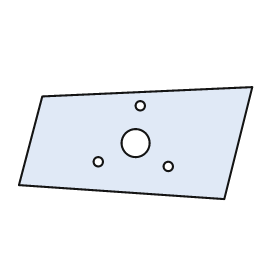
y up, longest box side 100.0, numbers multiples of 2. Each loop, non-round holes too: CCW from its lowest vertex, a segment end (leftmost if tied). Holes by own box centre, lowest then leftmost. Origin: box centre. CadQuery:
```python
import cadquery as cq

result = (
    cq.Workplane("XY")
    .moveTo(38.0, -24.0)
    .lineTo(50.0, 24.0)
    .lineTo(-40.0, 20.0)
    .lineTo(-50.0, -18.0)
    .close()
    .moveTo(14.0, -10.0)
    .circle(2.0)
    .moveTo(-16.0, -8.0)
    .circle(2.0)
    .moveTo(0.0, 0.0)
    .circle(6.0)
    .moveTo(2.0, 16.0)
    .circle(2.0)
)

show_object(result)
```